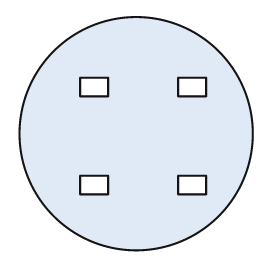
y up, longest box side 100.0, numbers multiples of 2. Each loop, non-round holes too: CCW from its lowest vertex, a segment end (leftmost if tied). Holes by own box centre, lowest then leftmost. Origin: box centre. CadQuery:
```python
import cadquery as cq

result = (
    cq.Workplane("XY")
    .moveTo(0.0, 0.0)
    .circle(50.0)
    .moveTo(-24.0, -26.0)
    .lineTo(-12.0, -26.0)
    .lineTo(-12.0, -18.0)
    .lineTo(-24.0, -18.0)
    .close()
    .moveTo(18.0, -26.0)
    .lineTo(30.0, -26.0)
    .lineTo(30.0, -18.0)
    .lineTo(18.0, -18.0)
    .close()
    .moveTo(-24.0, 16.0)
    .lineTo(-12.0, 16.0)
    .lineTo(-12.0, 24.0)
    .lineTo(-24.0, 24.0)
    .close()
    .moveTo(18.0, 16.0)
    .lineTo(30.0, 16.0)
    .lineTo(30.0, 24.0)
    .lineTo(18.0, 24.0)
    .close()
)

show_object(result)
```